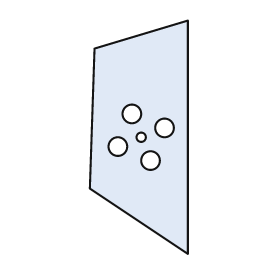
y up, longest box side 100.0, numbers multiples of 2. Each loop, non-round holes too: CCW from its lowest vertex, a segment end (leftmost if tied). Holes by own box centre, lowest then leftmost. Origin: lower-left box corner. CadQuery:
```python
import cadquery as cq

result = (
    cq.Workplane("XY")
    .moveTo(42.0, 0.0)
    .lineTo(42.0, 100.0)
    .lineTo(2.0, 88.0)
    .lineTo(0.0, 28.0)
    .close()
    .moveTo(26.0, 40.0)
    .circle(4.0)
    .moveTo(12.0, 46.0)
    .circle(4.0)
    .moveTo(22.0, 50.0)
    .circle(2.0)
    .moveTo(32.0, 54.0)
    .circle(4.0)
    .moveTo(18.0, 60.0)
    .circle(4.0)
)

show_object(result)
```